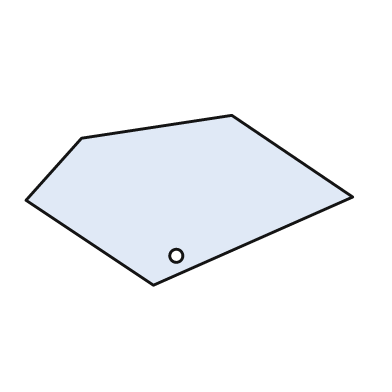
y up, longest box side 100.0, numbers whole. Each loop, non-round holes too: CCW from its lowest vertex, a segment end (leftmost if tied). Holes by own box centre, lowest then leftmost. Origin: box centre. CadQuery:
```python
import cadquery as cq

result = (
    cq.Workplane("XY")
    .moveTo(-11.0, -26.0)
    .lineTo(50.0, 1.0)
    .lineTo(13.0, 26.0)
    .lineTo(-33.0, 19.0)
    .lineTo(-50.0, 0.0)
    .close()
    .moveTo(-4.0, -17.0)
    .circle(2.0)
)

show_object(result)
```